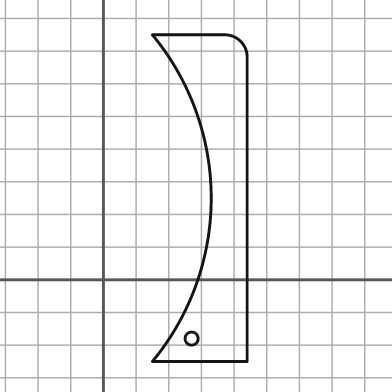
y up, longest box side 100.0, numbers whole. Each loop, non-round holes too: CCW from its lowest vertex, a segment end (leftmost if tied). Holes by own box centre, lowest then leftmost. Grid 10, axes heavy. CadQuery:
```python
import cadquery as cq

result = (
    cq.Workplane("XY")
    .moveTo(15.0, -25.0)
    .lineTo(44.0, -25.0)
    .lineTo(44.0, 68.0)
    .threePointArc((42.0, 73.0), (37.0, 75.0))
    .lineTo(15.0, 75.0)
    .threePointArc((33.0, 25.0), (15.0, -25.0))
    .close()
    .moveTo(27.0, -18.0)
    .circle(2.0)
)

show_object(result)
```